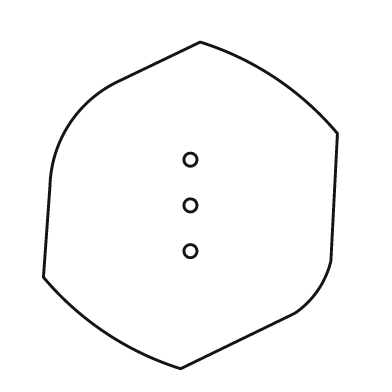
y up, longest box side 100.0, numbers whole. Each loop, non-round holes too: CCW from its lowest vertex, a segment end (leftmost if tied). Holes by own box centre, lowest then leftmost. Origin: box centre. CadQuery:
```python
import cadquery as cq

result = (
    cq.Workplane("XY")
    .moveTo(-3.0, -50.0)
    .lineTo(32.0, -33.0)
    .threePointArc((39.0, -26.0), (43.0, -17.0))
    .lineTo(45.0, 22.0)
    .threePointArc((26.0, 39.0), (3.0, 50.0))
    .lineTo(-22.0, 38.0)
    .threePointArc((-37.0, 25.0), (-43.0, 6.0))
    .lineTo(-45.0, -22.0)
    .threePointArc((-26.0, -39.0), (-3.0, -50.0))
    .close()
    .moveTo(0.0, -14.0)
    .circle(2.0)
    .moveTo(0.0, 0.0)
    .circle(2.0)
    .moveTo(0.0, 14.0)
    .circle(2.0)
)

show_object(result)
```